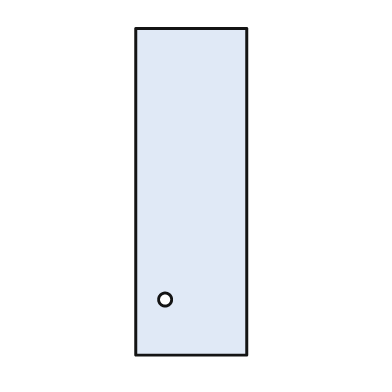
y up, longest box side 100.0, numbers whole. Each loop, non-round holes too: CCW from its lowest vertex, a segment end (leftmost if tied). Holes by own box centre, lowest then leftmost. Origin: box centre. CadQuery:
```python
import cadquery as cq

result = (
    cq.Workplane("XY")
    .moveTo(-17.0, -50.0)
    .lineTo(17.0, -50.0)
    .lineTo(17.0, 50.0)
    .lineTo(-17.0, 50.0)
    .close()
    .moveTo(-8.0, -33.0)
    .circle(2.0)
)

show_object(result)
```